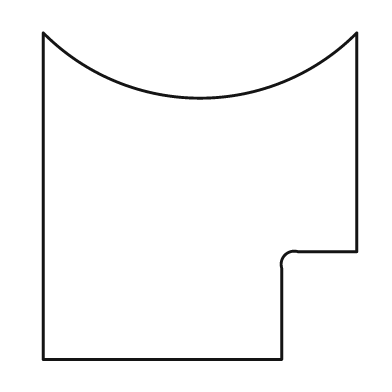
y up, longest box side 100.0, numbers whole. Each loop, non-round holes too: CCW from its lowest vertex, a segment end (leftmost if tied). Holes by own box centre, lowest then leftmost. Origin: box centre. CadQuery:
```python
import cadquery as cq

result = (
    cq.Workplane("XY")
    .moveTo(-48.0, -50.0)
    .lineTo(25.0, -50.0)
    .lineTo(25.0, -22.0)
    .threePointArc((26.0, -18.0), (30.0, -17.0))
    .lineTo(48.0, -17.0)
    .lineTo(48.0, 50.0)
    .threePointArc((0.0, 30.0), (-48.0, 50.0))
    .close()
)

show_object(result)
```